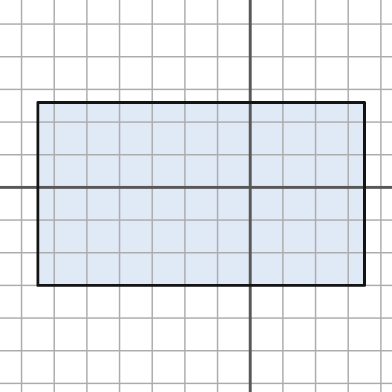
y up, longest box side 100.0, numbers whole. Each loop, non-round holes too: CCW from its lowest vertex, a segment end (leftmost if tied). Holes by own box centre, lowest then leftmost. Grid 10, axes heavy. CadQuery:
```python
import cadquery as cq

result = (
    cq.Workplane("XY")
    .moveTo(-65.0, -30.0)
    .lineTo(35.0, -30.0)
    .lineTo(35.0, 26.0)
    .lineTo(-65.0, 26.0)
    .close()
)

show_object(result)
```